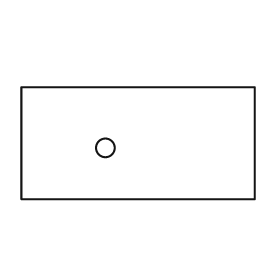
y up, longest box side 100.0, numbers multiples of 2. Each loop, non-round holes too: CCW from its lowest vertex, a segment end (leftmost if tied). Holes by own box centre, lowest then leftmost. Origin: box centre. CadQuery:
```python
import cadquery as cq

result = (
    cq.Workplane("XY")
    .moveTo(-50.0, -24.0)
    .lineTo(50.0, -24.0)
    .lineTo(50.0, 24.0)
    .lineTo(-50.0, 24.0)
    .close()
    .moveTo(-14.0, -2.0)
    .circle(4.0)
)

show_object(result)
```